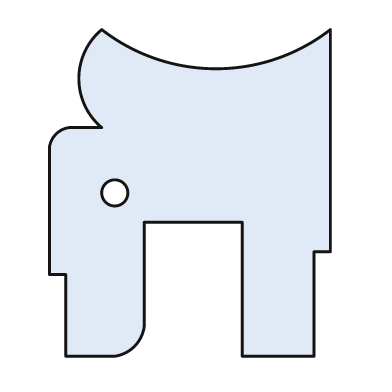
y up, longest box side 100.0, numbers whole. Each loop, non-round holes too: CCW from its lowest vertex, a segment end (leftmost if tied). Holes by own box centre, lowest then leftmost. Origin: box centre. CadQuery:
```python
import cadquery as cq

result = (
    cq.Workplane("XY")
    .moveTo(-38.0, -50.0)
    .lineTo(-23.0, -50.0)
    .threePointArc((-17.0, -47.0), (-14.0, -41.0))
    .lineTo(-14.0, -9.0)
    .lineTo(16.0, -9.0)
    .lineTo(16.0, -50.0)
    .lineTo(38.0, -50.0)
    .lineTo(38.0, -18.0)
    .lineTo(43.0, -18.0)
    .lineTo(43.0, 50.0)
    .threePointArc((8.0, 38.0), (-27.0, 50.0))
    .threePointArc((-34.0, 35.0), (-27.0, 20.0))
    .lineTo(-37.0, 20.0)
    .threePointArc((-41.0, 18.0), (-43.0, 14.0))
    .lineTo(-43.0, -25.0)
    .lineTo(-38.0, -25.0)
    .close()
    .moveTo(-23.0, 0.0)
    .circle(4.0)
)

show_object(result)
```